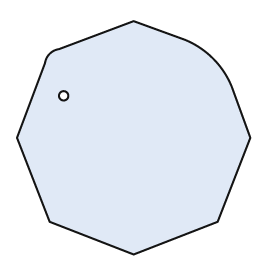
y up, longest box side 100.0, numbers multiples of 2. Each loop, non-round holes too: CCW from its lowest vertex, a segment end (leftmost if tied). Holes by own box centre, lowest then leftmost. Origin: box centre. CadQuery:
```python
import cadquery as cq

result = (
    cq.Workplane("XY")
    .moveTo(0.0, -50.0)
    .lineTo(36.0, -36.0)
    .lineTo(50.0, 0.0)
    .lineTo(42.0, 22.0)
    .threePointArc((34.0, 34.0), (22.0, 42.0))
    .lineTo(0.0, 50.0)
    .lineTo(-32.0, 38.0)
    .threePointArc((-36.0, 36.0), (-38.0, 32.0))
    .lineTo(-50.0, 0.0)
    .lineTo(-36.0, -36.0)
    .close()
    .moveTo(-30.0, 18.0)
    .circle(2.0)
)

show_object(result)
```